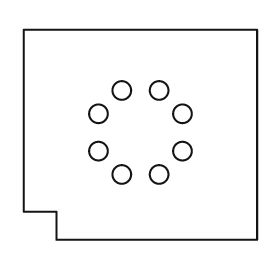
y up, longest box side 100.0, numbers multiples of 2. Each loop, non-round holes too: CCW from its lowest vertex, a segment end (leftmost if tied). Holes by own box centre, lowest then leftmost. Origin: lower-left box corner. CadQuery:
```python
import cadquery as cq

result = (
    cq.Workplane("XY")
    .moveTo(14.0, 0.0)
    .lineTo(100.0, 0.0)
    .lineTo(100.0, 90.0)
    .lineTo(0.0, 90.0)
    .lineTo(0.0, 12.0)
    .lineTo(14.0, 12.0)
    .close()
    .moveTo(42.0, 28.0)
    .circle(4.0)
    .moveTo(58.0, 28.0)
    .circle(4.0)
    .moveTo(32.0, 38.0)
    .circle(4.0)
    .moveTo(68.0, 38.0)
    .circle(4.0)
    .moveTo(32.0, 54.0)
    .circle(4.0)
    .moveTo(68.0, 54.0)
    .circle(4.0)
    .moveTo(42.0, 64.0)
    .circle(4.0)
    .moveTo(58.0, 64.0)
    .circle(4.0)
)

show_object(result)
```